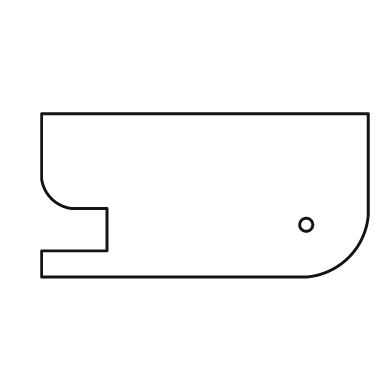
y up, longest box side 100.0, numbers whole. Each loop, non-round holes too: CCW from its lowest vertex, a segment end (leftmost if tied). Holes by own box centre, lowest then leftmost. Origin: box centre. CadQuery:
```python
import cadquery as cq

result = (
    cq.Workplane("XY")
    .moveTo(-50.0, -25.0)
    .lineTo(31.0, -25.0)
    .threePointArc((44.0, -19.0), (50.0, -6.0))
    .lineTo(50.0, 25.0)
    .lineTo(-50.0, 25.0)
    .lineTo(-50.0, 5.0)
    .threePointArc((-47.0, -1.0), (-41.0, -4.0))
    .lineTo(-30.0, -4.0)
    .lineTo(-30.0, -17.0)
    .lineTo(-50.0, -17.0)
    .close()
    .moveTo(31.0, -9.0)
    .circle(2.0)
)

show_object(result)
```